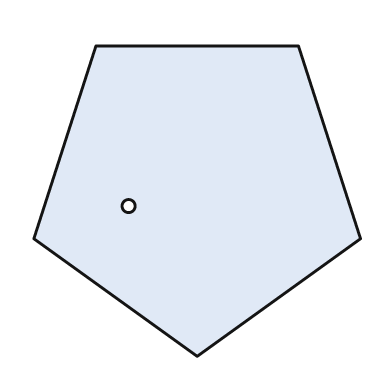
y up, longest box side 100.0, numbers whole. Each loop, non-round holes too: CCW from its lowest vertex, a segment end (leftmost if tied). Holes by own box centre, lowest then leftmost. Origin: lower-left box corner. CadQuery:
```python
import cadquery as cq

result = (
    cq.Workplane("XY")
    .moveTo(50.0, 0.0)
    .lineTo(100.0, 36.0)
    .lineTo(81.0, 95.0)
    .lineTo(19.0, 95.0)
    .lineTo(0.0, 36.0)
    .close()
    .moveTo(29.0, 46.0)
    .circle(2.0)
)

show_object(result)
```